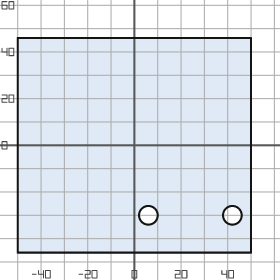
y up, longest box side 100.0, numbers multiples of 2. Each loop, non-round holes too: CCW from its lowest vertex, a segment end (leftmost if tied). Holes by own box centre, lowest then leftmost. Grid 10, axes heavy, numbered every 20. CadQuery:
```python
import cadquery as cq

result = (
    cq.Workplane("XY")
    .moveTo(-50.0, -46.0)
    .lineTo(50.0, -46.0)
    .lineTo(50.0, 46.0)
    .lineTo(-50.0, 46.0)
    .close()
    .moveTo(6.0, -30.0)
    .circle(4.0)
    .moveTo(42.0, -30.0)
    .circle(4.0)
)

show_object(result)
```